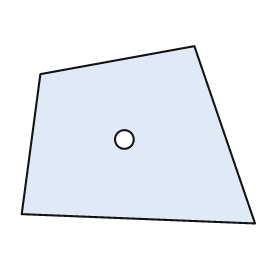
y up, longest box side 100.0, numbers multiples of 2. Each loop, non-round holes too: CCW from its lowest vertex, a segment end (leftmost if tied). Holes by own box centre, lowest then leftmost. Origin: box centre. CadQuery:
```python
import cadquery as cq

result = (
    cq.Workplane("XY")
    .moveTo(50.0, -38.0)
    .lineTo(24.0, 38.0)
    .lineTo(-42.0, 26.0)
    .lineTo(-50.0, -34.0)
    .close()
    .moveTo(-6.0, -2.0)
    .circle(4.0)
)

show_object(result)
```